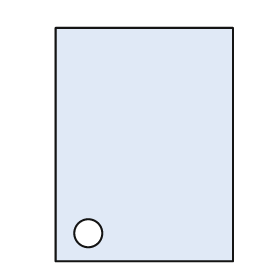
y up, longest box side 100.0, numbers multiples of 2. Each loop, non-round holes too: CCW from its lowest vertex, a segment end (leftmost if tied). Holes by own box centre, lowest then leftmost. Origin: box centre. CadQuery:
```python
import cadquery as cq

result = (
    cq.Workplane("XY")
    .moveTo(-38.0, -50.0)
    .lineTo(38.0, -50.0)
    .lineTo(38.0, 50.0)
    .lineTo(-38.0, 50.0)
    .close()
    .moveTo(-24.0, -38.0)
    .circle(6.0)
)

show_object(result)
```